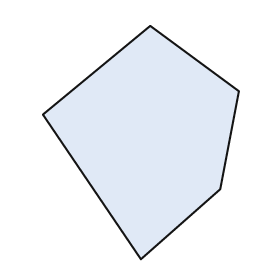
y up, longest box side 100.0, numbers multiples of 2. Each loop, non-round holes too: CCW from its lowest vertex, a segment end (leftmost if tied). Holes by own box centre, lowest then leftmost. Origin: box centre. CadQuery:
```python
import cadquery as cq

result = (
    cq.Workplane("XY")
    .moveTo(0.0, -50.0)
    .lineTo(34.0, -20.0)
    .lineTo(42.0, 22.0)
    .lineTo(4.0, 50.0)
    .lineTo(-42.0, 12.0)
    .close()
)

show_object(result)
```